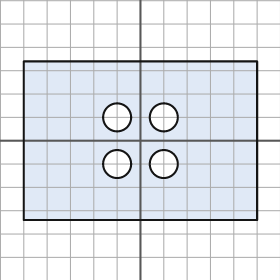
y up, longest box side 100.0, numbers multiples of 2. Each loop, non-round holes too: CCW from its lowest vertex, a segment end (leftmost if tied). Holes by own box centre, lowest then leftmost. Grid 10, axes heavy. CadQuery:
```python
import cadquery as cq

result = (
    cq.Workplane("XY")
    .moveTo(-50.0, -34.0)
    .lineTo(50.0, -34.0)
    .lineTo(50.0, 34.0)
    .lineTo(-50.0, 34.0)
    .close()
    .moveTo(-10.0, -10.0)
    .circle(6.0)
    .moveTo(10.0, -10.0)
    .circle(6.0)
    .moveTo(-10.0, 10.0)
    .circle(6.0)
    .moveTo(10.0, 10.0)
    .circle(6.0)
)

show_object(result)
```